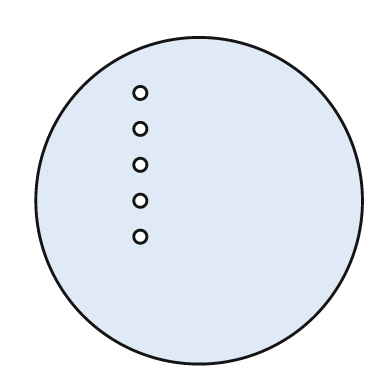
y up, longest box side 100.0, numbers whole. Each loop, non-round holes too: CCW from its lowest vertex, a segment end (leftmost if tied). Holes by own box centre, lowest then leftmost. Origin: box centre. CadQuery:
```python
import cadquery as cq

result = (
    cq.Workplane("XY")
    .moveTo(0.0, 0.0)
    .circle(50.0)
    .moveTo(-18.0, -11.0)
    .circle(2.0)
    .moveTo(-18.0, 0.0)
    .circle(2.0)
    .moveTo(-18.0, 11.0)
    .circle(2.0)
    .moveTo(-18.0, 22.0)
    .circle(2.0)
    .moveTo(-18.0, 33.0)
    .circle(2.0)
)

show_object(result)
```